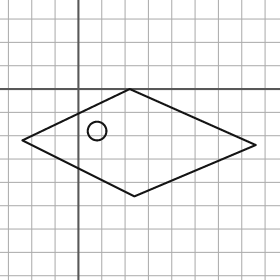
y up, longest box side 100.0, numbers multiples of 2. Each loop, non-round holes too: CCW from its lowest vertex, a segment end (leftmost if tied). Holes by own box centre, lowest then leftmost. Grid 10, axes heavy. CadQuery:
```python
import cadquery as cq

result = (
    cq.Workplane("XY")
    .moveTo(24.0, -46.0)
    .lineTo(76.0, -24.0)
    .lineTo(22.0, 0.0)
    .lineTo(-24.0, -22.0)
    .close()
    .moveTo(8.0, -18.0)
    .circle(4.0)
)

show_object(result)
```